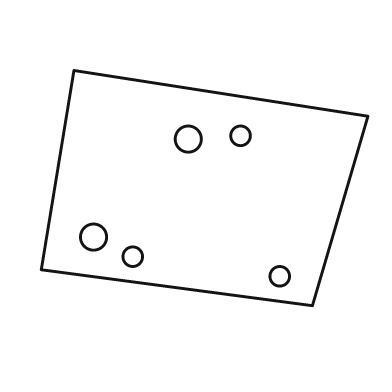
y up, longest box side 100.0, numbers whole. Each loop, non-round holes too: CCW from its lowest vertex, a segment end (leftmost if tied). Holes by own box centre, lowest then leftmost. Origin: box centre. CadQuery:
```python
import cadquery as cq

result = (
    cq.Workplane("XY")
    .moveTo(33.0, -36.0)
    .lineTo(50.0, 22.0)
    .lineTo(-40.0, 36.0)
    .lineTo(-50.0, -25.0)
    .close()
    .moveTo(23.0, -27.0)
    .circle(3.0)
    .moveTo(-22.0, -21.0)
    .circle(3.0)
    .moveTo(-34.0, -15.0)
    .circle(4.0)
    .moveTo(-5.0, 15.0)
    .circle(4.0)
    .moveTo(11.0, 16.0)
    .circle(3.0)
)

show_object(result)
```